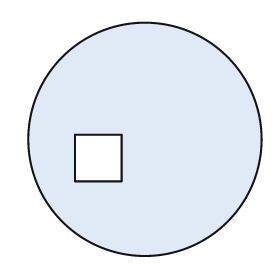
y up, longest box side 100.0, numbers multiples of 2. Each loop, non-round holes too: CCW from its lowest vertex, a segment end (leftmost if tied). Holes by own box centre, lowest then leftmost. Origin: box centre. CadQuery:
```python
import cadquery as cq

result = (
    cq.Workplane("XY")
    .moveTo(0.0, 0.0)
    .circle(50.0)
    .moveTo(-30.0, -18.0)
    .lineTo(-10.0, -18.0)
    .lineTo(-10.0, 2.0)
    .lineTo(-30.0, 2.0)
    .close()
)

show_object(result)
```